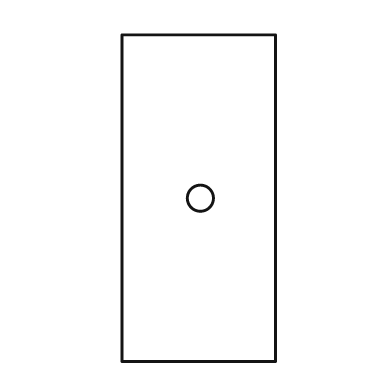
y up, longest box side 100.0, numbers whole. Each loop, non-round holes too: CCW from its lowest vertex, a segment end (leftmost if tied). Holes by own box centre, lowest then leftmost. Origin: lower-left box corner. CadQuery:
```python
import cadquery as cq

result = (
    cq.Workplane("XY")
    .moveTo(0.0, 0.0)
    .lineTo(47.0, 0.0)
    .lineTo(47.0, 100.0)
    .lineTo(0.0, 100.0)
    .close()
    .moveTo(24.0, 50.0)
    .circle(4.0)
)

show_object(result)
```